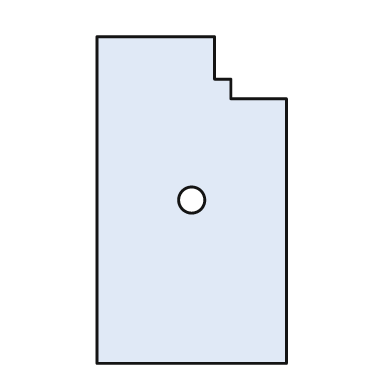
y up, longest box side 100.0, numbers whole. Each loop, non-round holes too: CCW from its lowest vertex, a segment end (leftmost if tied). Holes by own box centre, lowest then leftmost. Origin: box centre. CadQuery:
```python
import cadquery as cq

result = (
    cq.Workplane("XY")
    .moveTo(-29.0, -50.0)
    .lineTo(29.0, -50.0)
    .lineTo(29.0, 31.0)
    .lineTo(12.0, 31.0)
    .lineTo(12.0, 37.0)
    .lineTo(7.0, 37.0)
    .lineTo(7.0, 50.0)
    .lineTo(-29.0, 50.0)
    .close()
    .moveTo(0.0, 0.0)
    .circle(4.0)
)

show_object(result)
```